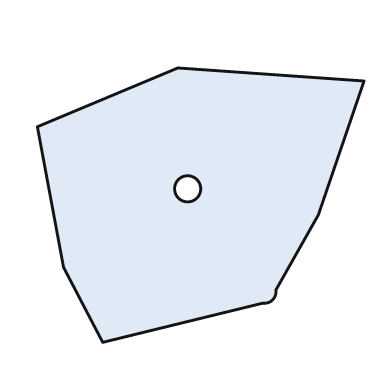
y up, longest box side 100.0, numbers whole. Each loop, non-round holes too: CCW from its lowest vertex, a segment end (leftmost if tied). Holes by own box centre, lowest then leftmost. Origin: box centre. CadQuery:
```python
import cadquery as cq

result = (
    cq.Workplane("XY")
    .moveTo(-30.0, -42.0)
    .lineTo(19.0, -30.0)
    .threePointArc((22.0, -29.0), (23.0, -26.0))
    .lineTo(36.0, -3.0)
    .lineTo(50.0, 38.0)
    .lineTo(-7.0, 42.0)
    .lineTo(-50.0, 24.0)
    .lineTo(-42.0, -19.0)
    .close()
    .moveTo(-4.0, 5.0)
    .circle(4.0)
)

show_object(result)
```